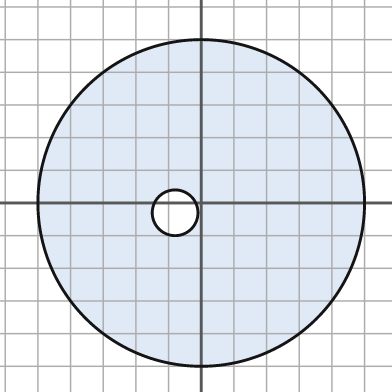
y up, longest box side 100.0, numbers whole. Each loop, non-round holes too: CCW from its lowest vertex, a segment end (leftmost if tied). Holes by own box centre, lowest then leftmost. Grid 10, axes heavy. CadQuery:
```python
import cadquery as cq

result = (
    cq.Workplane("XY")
    .moveTo(0.0, 0.0)
    .circle(50.0)
    .moveTo(-8.0, -3.0)
    .circle(7.0)
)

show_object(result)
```